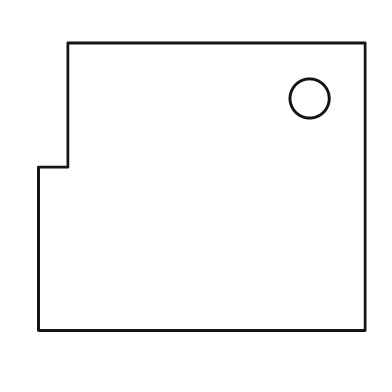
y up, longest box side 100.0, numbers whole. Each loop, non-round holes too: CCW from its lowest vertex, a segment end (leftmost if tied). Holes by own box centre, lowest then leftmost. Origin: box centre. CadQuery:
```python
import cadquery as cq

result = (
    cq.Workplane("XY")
    .moveTo(-50.0, -44.0)
    .lineTo(50.0, -44.0)
    .lineTo(50.0, 44.0)
    .lineTo(-41.0, 44.0)
    .lineTo(-41.0, 6.0)
    .lineTo(-50.0, 6.0)
    .close()
    .moveTo(33.0, 27.0)
    .circle(6.0)
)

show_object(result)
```